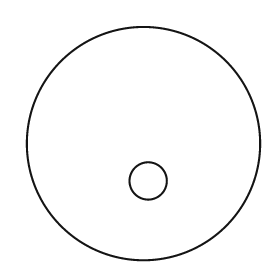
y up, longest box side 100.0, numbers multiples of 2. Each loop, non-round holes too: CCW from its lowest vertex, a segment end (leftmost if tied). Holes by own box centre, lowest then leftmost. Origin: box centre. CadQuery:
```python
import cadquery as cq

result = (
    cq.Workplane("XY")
    .moveTo(0.0, 0.0)
    .circle(50.0)
    .moveTo(2.0, -16.0)
    .circle(8.0)
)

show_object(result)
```